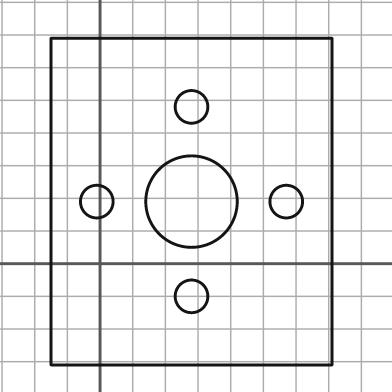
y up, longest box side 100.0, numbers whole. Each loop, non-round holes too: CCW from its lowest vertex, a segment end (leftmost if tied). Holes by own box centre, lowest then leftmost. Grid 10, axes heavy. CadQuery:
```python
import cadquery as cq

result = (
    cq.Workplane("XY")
    .moveTo(-15.0, -31.0)
    .lineTo(71.0, -31.0)
    .lineTo(71.0, 69.0)
    .lineTo(-15.0, 69.0)
    .close()
    .moveTo(28.0, -10.0)
    .circle(5.0)
    .moveTo(-1.0, 19.0)
    .circle(5.0)
    .moveTo(28.0, 19.0)
    .circle(14.0)
    .moveTo(57.0, 19.0)
    .circle(5.0)
    .moveTo(28.0, 48.0)
    .circle(5.0)
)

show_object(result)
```